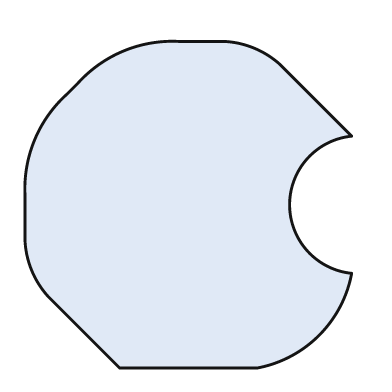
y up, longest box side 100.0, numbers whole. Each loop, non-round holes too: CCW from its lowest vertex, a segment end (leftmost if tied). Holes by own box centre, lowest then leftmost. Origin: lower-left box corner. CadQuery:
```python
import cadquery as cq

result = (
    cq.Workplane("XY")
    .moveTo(29.0, 0.0)
    .lineTo(71.0, 0.0)
    .threePointArc((90.0, 10.0), (100.0, 29.0))
    .threePointArc((81.0, 50.0), (100.0, 71.0))
    .lineTo(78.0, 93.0)
    .threePointArc((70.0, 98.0), (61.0, 100.0))
    .lineTo(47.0, 100.0)
    .threePointArc((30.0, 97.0), (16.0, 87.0))
    .lineTo(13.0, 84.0)
    .threePointArc((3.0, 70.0), (0.0, 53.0))
    .lineTo(0.0, 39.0)
    .threePointArc((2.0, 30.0), (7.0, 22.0))
    .close()
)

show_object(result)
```